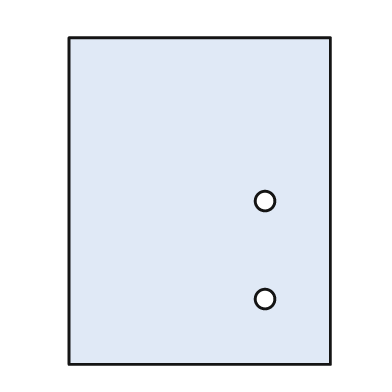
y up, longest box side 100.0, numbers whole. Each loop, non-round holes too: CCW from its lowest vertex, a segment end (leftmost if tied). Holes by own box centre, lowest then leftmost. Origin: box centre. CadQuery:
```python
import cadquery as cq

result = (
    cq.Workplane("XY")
    .moveTo(-40.0, -50.0)
    .lineTo(40.0, -50.0)
    .lineTo(40.0, 50.0)
    .lineTo(-40.0, 50.0)
    .close()
    .moveTo(20.0, -30.0)
    .circle(3.0)
    .moveTo(20.0, 0.0)
    .circle(3.0)
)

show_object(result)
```